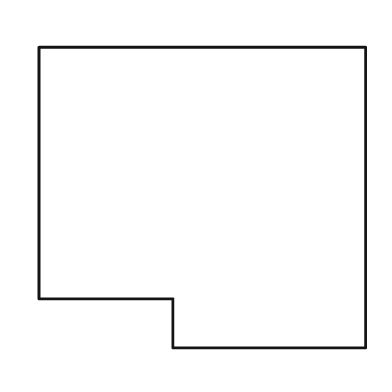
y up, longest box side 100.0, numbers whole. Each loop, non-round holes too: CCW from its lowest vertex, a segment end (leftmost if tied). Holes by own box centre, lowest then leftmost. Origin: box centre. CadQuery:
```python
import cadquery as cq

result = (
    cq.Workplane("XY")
    .moveTo(-9.0, -46.0)
    .lineTo(50.0, -46.0)
    .lineTo(50.0, 46.0)
    .lineTo(-50.0, 46.0)
    .lineTo(-50.0, -31.0)
    .lineTo(-9.0, -31.0)
    .close()
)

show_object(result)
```